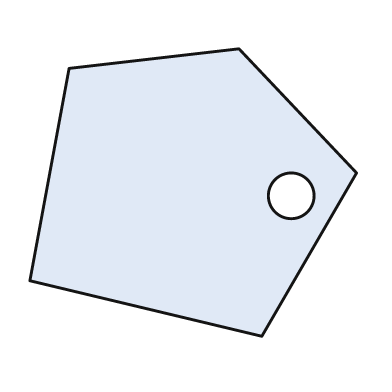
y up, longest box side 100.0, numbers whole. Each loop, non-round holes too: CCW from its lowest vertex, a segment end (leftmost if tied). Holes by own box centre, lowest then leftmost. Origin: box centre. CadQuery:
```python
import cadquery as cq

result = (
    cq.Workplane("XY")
    .moveTo(21.0, -44.0)
    .lineTo(50.0, 6.0)
    .lineTo(14.0, 44.0)
    .lineTo(-38.0, 38.0)
    .lineTo(-50.0, -27.0)
    .close()
    .moveTo(30.0, -1.0)
    .circle(7.0)
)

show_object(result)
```